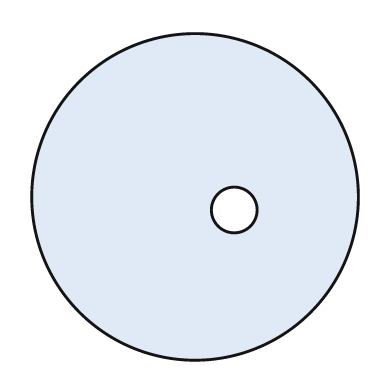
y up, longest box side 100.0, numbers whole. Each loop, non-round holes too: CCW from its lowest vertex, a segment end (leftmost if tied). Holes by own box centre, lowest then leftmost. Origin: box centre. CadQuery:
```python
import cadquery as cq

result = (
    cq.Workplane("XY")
    .moveTo(0.0, 0.0)
    .circle(50.0)
    .moveTo(12.0, -4.0)
    .circle(7.0)
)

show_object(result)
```